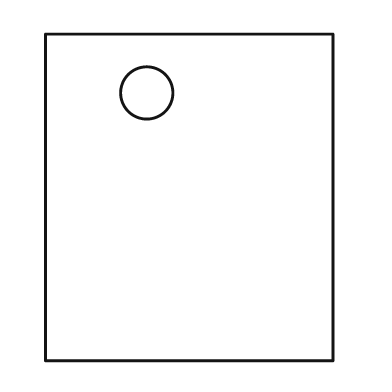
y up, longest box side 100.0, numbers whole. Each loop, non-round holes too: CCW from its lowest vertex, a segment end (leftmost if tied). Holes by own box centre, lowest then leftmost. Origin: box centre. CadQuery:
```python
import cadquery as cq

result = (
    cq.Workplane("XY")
    .moveTo(-44.0, -50.0)
    .lineTo(44.0, -50.0)
    .lineTo(44.0, 50.0)
    .lineTo(-44.0, 50.0)
    .close()
    .moveTo(-13.0, 32.0)
    .circle(8.0)
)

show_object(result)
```